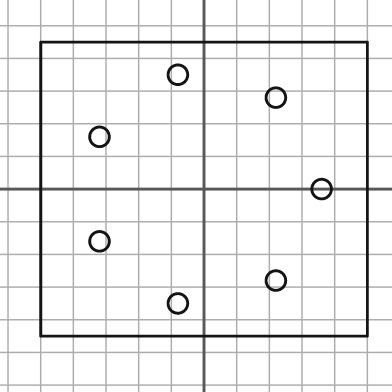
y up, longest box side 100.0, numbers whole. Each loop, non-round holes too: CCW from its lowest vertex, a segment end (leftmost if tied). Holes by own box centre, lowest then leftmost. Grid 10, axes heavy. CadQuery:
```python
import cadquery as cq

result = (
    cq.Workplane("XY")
    .moveTo(-50.0, -45.0)
    .lineTo(50.0, -45.0)
    .lineTo(50.0, 45.0)
    .lineTo(-50.0, 45.0)
    .close()
    .moveTo(-8.0, -35.0)
    .circle(3.0)
    .moveTo(22.0, -28.0)
    .circle(3.0)
    .moveTo(-32.0, -16.0)
    .circle(3.0)
    .moveTo(36.0, 0.0)
    .circle(3.0)
    .moveTo(-32.0, 16.0)
    .circle(3.0)
    .moveTo(22.0, 28.0)
    .circle(3.0)
    .moveTo(-8.0, 35.0)
    .circle(3.0)
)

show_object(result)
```